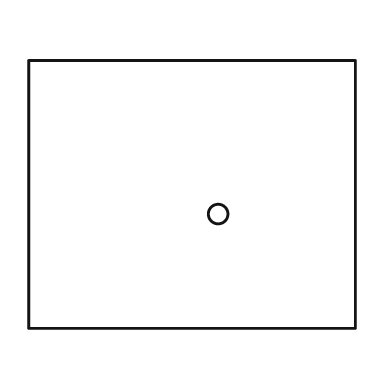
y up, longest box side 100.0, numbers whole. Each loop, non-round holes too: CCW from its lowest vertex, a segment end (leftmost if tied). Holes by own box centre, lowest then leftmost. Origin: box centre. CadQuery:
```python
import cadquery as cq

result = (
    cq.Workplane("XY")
    .moveTo(-50.0, -41.0)
    .lineTo(50.0, -41.0)
    .lineTo(50.0, 41.0)
    .lineTo(-50.0, 41.0)
    .close()
    .moveTo(8.0, -6.0)
    .circle(3.0)
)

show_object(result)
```